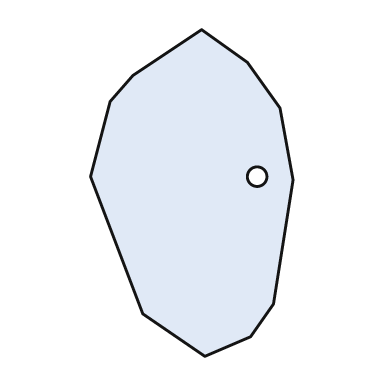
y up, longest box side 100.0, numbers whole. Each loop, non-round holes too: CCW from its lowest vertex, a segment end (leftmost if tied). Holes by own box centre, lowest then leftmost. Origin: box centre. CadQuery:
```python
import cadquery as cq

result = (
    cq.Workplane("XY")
    .moveTo(4.0, -50.0)
    .lineTo(18.0, -44.0)
    .lineTo(25.0, -34.0)
    .lineTo(31.0, 4.0)
    .lineTo(27.0, 26.0)
    .lineTo(17.0, 40.0)
    .lineTo(3.0, 50.0)
    .lineTo(-18.0, 36.0)
    .lineTo(-25.0, 28.0)
    .lineTo(-31.0, 5.0)
    .lineTo(-15.0, -37.0)
    .close()
    .moveTo(20.0, 5.0)
    .circle(3.0)
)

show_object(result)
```